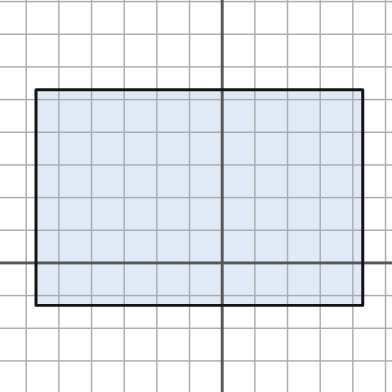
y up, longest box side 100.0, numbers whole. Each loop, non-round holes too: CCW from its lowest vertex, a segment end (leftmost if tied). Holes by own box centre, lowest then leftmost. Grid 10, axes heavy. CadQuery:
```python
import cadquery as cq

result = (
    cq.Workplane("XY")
    .moveTo(-57.0, -13.0)
    .lineTo(43.0, -13.0)
    .lineTo(43.0, 53.0)
    .lineTo(-57.0, 53.0)
    .close()
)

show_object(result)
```